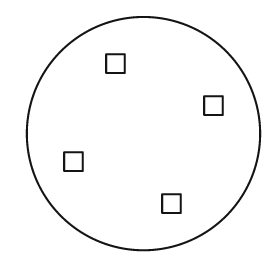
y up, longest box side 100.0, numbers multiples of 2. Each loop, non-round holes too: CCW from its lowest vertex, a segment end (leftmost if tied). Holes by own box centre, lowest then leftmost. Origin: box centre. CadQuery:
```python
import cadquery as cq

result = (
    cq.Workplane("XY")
    .moveTo(0.0, 0.0)
    .circle(50.0)
    .moveTo(8.0, -34.0)
    .lineTo(16.0, -34.0)
    .lineTo(16.0, -26.0)
    .lineTo(8.0, -26.0)
    .close()
    .moveTo(-34.0, -16.0)
    .lineTo(-26.0, -16.0)
    .lineTo(-26.0, -8.0)
    .lineTo(-34.0, -8.0)
    .close()
    .moveTo(26.0, 8.0)
    .lineTo(34.0, 8.0)
    .lineTo(34.0, 16.0)
    .lineTo(26.0, 16.0)
    .close()
    .moveTo(-16.0, 26.0)
    .lineTo(-8.0, 26.0)
    .lineTo(-8.0, 34.0)
    .lineTo(-16.0, 34.0)
    .close()
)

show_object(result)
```